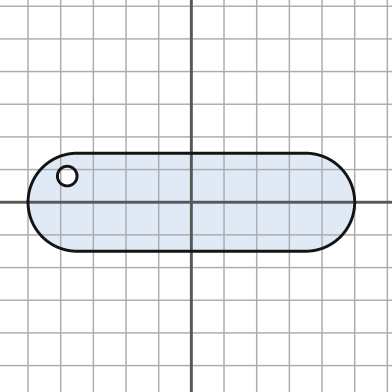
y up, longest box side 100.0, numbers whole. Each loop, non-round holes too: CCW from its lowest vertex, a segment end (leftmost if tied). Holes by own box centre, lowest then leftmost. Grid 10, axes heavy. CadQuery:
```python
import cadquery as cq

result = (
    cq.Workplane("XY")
    .moveTo(-35.0, -15.0)
    .lineTo(35.0, -15.0)
    .threePointArc((50.0, 0.0), (35.0, 15.0))
    .lineTo(-35.0, 15.0)
    .threePointArc((-50.0, 0.0), (-35.0, -15.0))
    .close()
    .moveTo(-38.0, 8.0)
    .circle(3.0)
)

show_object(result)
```